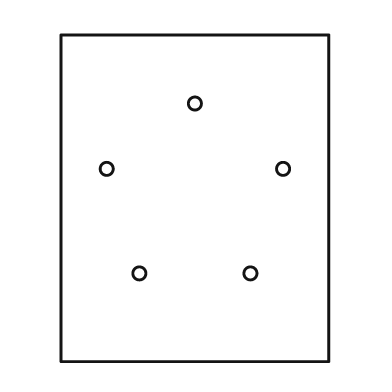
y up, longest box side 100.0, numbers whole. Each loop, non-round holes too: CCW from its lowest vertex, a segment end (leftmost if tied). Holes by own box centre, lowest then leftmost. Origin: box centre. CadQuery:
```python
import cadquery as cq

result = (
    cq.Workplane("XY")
    .moveTo(-41.0, -50.0)
    .lineTo(41.0, -50.0)
    .lineTo(41.0, 50.0)
    .lineTo(-41.0, 50.0)
    .close()
    .moveTo(-17.0, -23.0)
    .circle(2.0)
    .moveTo(17.0, -23.0)
    .circle(2.0)
    .moveTo(-27.0, 9.0)
    .circle(2.0)
    .moveTo(27.0, 9.0)
    .circle(2.0)
    .moveTo(0.0, 29.0)
    .circle(2.0)
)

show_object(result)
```